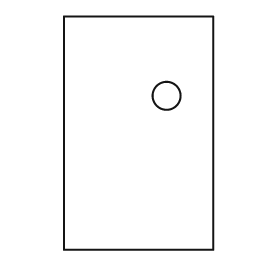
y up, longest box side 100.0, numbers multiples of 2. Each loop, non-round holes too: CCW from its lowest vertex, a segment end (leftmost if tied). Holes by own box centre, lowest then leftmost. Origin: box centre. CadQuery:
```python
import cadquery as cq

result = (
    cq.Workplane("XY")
    .moveTo(-32.0, -50.0)
    .lineTo(32.0, -50.0)
    .lineTo(32.0, 50.0)
    .lineTo(-32.0, 50.0)
    .close()
    .moveTo(12.0, 16.0)
    .circle(6.0)
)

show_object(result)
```